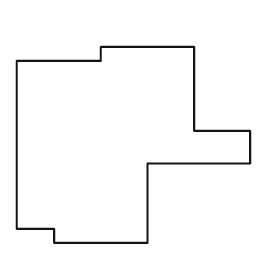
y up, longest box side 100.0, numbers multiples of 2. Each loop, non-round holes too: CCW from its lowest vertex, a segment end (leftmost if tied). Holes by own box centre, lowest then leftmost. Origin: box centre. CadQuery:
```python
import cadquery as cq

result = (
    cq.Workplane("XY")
    .moveTo(-34.0, -42.0)
    .lineTo(6.0, -42.0)
    .lineTo(6.0, -8.0)
    .lineTo(50.0, -8.0)
    .lineTo(50.0, 6.0)
    .lineTo(26.0, 6.0)
    .lineTo(26.0, 42.0)
    .lineTo(-14.0, 42.0)
    .lineTo(-14.0, 36.0)
    .lineTo(-50.0, 36.0)
    .lineTo(-50.0, -36.0)
    .lineTo(-34.0, -36.0)
    .close()
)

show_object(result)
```